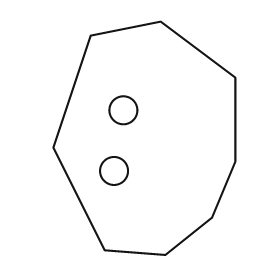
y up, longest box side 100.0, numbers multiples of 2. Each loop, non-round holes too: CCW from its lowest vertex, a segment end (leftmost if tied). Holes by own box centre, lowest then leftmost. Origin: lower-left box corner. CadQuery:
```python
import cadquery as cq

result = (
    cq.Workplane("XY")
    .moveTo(48.0, 0.0)
    .lineTo(68.0, 16.0)
    .lineTo(78.0, 40.0)
    .lineTo(78.0, 76.0)
    .lineTo(46.0, 100.0)
    .lineTo(16.0, 94.0)
    .lineTo(0.0, 46.0)
    .lineTo(22.0, 2.0)
    .close()
    .moveTo(26.0, 36.0)
    .circle(6.0)
    .moveTo(30.0, 62.0)
    .circle(6.0)
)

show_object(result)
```